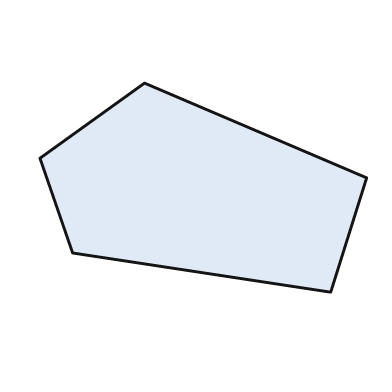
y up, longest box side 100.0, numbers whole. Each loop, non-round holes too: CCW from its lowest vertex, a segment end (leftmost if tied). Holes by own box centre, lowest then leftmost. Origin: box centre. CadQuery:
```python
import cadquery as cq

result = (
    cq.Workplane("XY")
    .moveTo(39.0, -32.0)
    .lineTo(50.0, 3.0)
    .lineTo(-18.0, 32.0)
    .lineTo(-50.0, 9.0)
    .lineTo(-40.0, -20.0)
    .close()
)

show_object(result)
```